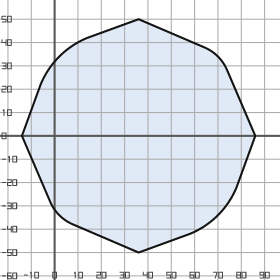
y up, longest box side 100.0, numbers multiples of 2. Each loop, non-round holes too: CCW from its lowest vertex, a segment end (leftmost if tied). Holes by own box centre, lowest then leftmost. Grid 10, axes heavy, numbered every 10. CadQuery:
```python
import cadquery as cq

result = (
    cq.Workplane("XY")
    .moveTo(36.0, -50.0)
    .lineTo(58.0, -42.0)
    .threePointArc((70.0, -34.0), (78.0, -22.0))
    .lineTo(86.0, 0.0)
    .lineTo(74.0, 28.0)
    .threePointArc((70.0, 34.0), (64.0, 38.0))
    .lineTo(36.0, 50.0)
    .lineTo(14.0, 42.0)
    .threePointArc((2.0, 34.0), (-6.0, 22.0))
    .lineTo(-14.0, 0.0)
    .lineTo(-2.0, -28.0)
    .threePointArc((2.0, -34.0), (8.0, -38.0))
    .close()
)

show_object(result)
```